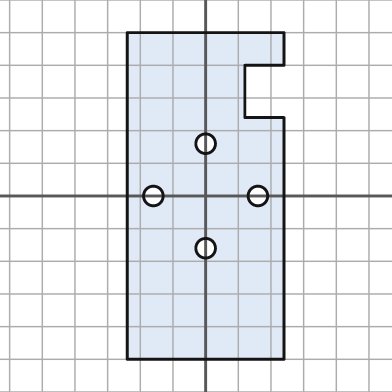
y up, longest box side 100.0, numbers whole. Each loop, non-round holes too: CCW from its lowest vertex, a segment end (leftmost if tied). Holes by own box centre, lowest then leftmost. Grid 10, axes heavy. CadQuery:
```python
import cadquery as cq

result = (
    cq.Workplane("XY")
    .moveTo(-24.0, -50.0)
    .lineTo(24.0, -50.0)
    .lineTo(24.0, 24.0)
    .lineTo(12.0, 24.0)
    .lineTo(12.0, 40.0)
    .lineTo(24.0, 40.0)
    .lineTo(24.0, 50.0)
    .lineTo(-24.0, 50.0)
    .close()
    .moveTo(0.0, -16.0)
    .circle(3.0)
    .moveTo(-16.0, 0.0)
    .circle(3.0)
    .moveTo(16.0, 0.0)
    .circle(3.0)
    .moveTo(0.0, 16.0)
    .circle(3.0)
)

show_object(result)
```